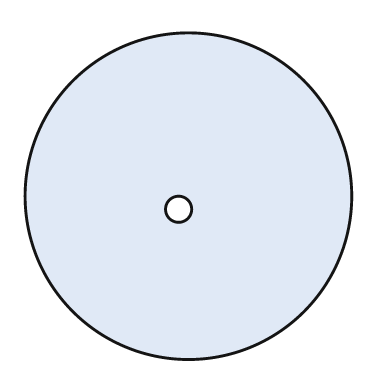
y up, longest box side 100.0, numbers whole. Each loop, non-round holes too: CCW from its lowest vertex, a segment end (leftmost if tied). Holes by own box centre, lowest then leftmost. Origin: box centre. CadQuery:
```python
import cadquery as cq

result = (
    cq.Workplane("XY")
    .moveTo(0.0, 0.0)
    .circle(50.0)
    .moveTo(-3.0, -4.0)
    .circle(4.0)
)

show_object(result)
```